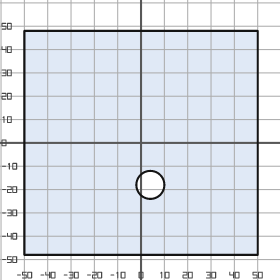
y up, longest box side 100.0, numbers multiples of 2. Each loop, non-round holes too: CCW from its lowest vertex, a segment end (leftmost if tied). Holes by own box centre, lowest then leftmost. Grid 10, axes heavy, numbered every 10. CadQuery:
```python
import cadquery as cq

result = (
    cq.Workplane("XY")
    .moveTo(-50.0, -48.0)
    .lineTo(50.0, -48.0)
    .lineTo(50.0, 48.0)
    .lineTo(-50.0, 48.0)
    .close()
    .moveTo(4.0, -18.0)
    .circle(6.0)
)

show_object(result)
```